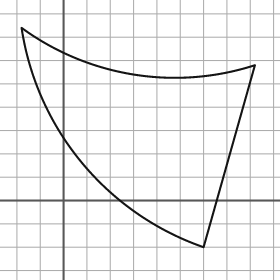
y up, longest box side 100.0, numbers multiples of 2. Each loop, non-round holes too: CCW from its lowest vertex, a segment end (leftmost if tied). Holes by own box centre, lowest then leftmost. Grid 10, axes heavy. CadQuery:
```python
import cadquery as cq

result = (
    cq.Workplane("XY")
    .moveTo(60.0, -20.0)
    .lineTo(82.0, 58.0)
    .threePointArc((30.0, 54.0), (-18.0, 74.0))
    .threePointArc((8.0, 16.0), (60.0, -20.0))
    .close()
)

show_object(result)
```